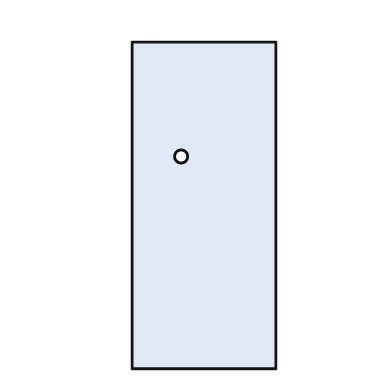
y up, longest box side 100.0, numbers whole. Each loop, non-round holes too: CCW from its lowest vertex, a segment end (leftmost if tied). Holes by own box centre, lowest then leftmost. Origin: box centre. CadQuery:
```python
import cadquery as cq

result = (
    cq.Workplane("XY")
    .moveTo(-22.0, -50.0)
    .lineTo(22.0, -50.0)
    .lineTo(22.0, 50.0)
    .lineTo(-22.0, 50.0)
    .close()
    .moveTo(-7.0, 15.0)
    .circle(2.0)
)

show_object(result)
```